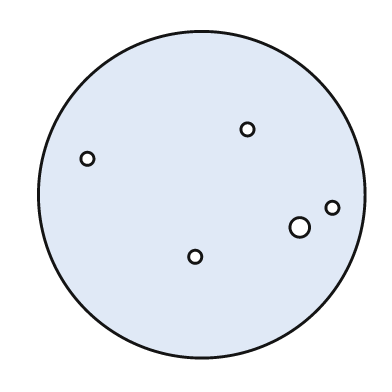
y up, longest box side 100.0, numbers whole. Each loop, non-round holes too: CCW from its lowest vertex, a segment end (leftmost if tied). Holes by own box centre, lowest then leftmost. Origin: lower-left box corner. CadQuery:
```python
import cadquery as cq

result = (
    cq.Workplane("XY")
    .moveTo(50.0, 50.0)
    .circle(50.0)
    .moveTo(48.0, 31.0)
    .circle(2.0)
    .moveTo(80.0, 40.0)
    .circle(3.0)
    .moveTo(90.0, 46.0)
    .circle(2.0)
    .moveTo(15.0, 61.0)
    .circle(2.0)
    .moveTo(64.0, 70.0)
    .circle(2.0)
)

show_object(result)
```